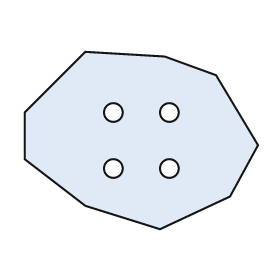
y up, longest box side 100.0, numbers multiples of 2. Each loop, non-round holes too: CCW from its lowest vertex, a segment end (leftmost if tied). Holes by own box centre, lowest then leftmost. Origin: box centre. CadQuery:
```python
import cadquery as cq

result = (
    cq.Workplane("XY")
    .moveTo(8.0, -38.0)
    .lineTo(38.0, -24.0)
    .lineTo(50.0, -2.0)
    .lineTo(32.0, 28.0)
    .lineTo(10.0, 36.0)
    .lineTo(-24.0, 38.0)
    .lineTo(-50.0, 12.0)
    .lineTo(-50.0, -8.0)
    .lineTo(-24.0, -28.0)
    .close()
    .moveTo(-12.0, -12.0)
    .circle(4.0)
    .moveTo(12.0, -12.0)
    .circle(4.0)
    .moveTo(-12.0, 12.0)
    .circle(4.0)
    .moveTo(12.0, 12.0)
    .circle(4.0)
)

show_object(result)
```